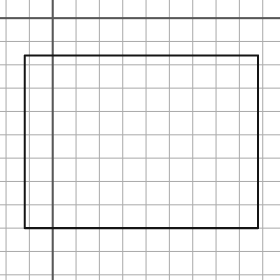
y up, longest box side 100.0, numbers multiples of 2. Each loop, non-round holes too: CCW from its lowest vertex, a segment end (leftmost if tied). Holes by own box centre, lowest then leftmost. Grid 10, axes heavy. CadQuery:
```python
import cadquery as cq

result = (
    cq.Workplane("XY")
    .moveTo(-12.0, -90.0)
    .lineTo(88.0, -90.0)
    .lineTo(88.0, -16.0)
    .lineTo(-12.0, -16.0)
    .close()
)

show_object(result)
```